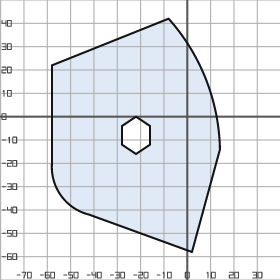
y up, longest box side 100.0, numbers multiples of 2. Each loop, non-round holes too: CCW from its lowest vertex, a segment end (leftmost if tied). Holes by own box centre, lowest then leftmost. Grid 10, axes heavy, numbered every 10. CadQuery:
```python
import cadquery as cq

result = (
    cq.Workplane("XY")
    .moveTo(2.0, -58.0)
    .lineTo(14.0, -14.0)
    .threePointArc((8.0, 16.0), (-8.0, 42.0))
    .lineTo(-58.0, 22.0)
    .lineTo(-58.0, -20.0)
    .threePointArc((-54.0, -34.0), (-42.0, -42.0))
    .close()
    .moveTo(-22.0, -16.0)
    .lineTo(-16.0, -12.0)
    .lineTo(-16.0, -4.0)
    .lineTo(-22.0, 0.0)
    .lineTo(-28.0, -4.0)
    .lineTo(-28.0, -12.0)
    .close()
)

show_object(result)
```